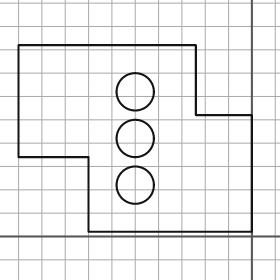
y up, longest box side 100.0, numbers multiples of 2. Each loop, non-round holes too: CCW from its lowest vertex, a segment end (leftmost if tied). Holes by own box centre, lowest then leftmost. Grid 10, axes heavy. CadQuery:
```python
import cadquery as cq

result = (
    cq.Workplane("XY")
    .moveTo(-70.0, 2.0)
    .lineTo(0.0, 2.0)
    .lineTo(0.0, 52.0)
    .lineTo(-24.0, 52.0)
    .lineTo(-24.0, 82.0)
    .lineTo(-100.0, 82.0)
    .lineTo(-100.0, 34.0)
    .lineTo(-70.0, 34.0)
    .close()
    .moveTo(-50.0, 22.0)
    .circle(8.0)
    .moveTo(-50.0, 42.0)
    .circle(8.0)
    .moveTo(-50.0, 62.0)
    .circle(8.0)
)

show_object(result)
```